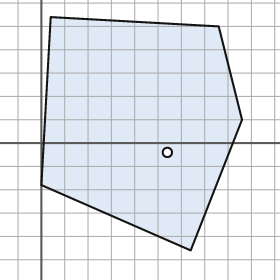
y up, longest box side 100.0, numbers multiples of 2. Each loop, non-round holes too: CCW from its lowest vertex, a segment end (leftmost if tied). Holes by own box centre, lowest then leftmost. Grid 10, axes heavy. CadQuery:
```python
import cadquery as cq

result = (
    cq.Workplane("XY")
    .moveTo(64.0, -46.0)
    .lineTo(86.0, 10.0)
    .lineTo(76.0, 50.0)
    .lineTo(4.0, 54.0)
    .lineTo(0.0, -18.0)
    .close()
    .moveTo(54.0, -4.0)
    .circle(2.0)
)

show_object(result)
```